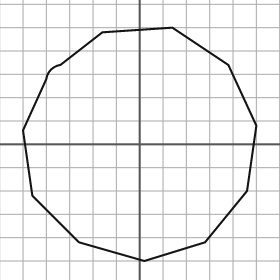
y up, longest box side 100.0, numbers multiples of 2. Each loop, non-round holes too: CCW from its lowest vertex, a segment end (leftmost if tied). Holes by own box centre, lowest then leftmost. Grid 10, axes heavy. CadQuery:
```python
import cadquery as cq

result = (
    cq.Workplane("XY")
    .moveTo(2.0, -50.0)
    .lineTo(28.0, -42.0)
    .lineTo(46.0, -20.0)
    .lineTo(50.0, 8.0)
    .lineTo(38.0, 34.0)
    .lineTo(14.0, 50.0)
    .lineTo(-16.0, 48.0)
    .lineTo(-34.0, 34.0)
    .threePointArc((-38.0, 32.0), (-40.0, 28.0))
    .lineTo(-50.0, 6.0)
    .lineTo(-46.0, -22.0)
    .lineTo(-26.0, -42.0)
    .close()
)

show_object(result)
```